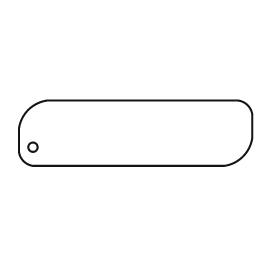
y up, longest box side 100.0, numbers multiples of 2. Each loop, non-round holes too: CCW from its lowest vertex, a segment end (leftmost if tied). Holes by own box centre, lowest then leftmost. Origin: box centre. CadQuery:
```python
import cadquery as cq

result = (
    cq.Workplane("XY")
    .moveTo(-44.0, -14.0)
    .lineTo(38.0, -14.0)
    .threePointArc((46.0, -10.0), (50.0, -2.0))
    .lineTo(50.0, 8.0)
    .threePointArc((48.0, 12.0), (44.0, 14.0))
    .lineTo(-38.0, 14.0)
    .threePointArc((-46.0, 10.0), (-50.0, 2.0))
    .lineTo(-50.0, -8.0)
    .threePointArc((-48.0, -12.0), (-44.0, -14.0))
    .close()
    .moveTo(-44.0, -6.0)
    .circle(2.0)
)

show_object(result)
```